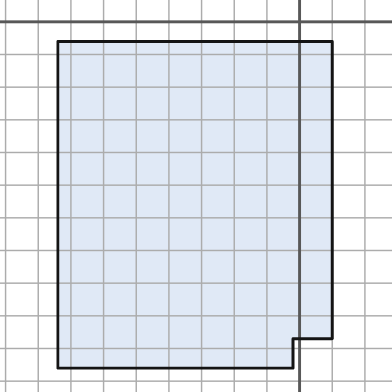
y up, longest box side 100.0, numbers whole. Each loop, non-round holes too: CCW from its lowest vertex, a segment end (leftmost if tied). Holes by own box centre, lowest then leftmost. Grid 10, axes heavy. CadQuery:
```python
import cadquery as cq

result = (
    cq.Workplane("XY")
    .moveTo(-74.0, -106.0)
    .lineTo(-2.0, -106.0)
    .lineTo(-2.0, -97.0)
    .lineTo(10.0, -97.0)
    .lineTo(10.0, -6.0)
    .lineTo(-74.0, -6.0)
    .close()
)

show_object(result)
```